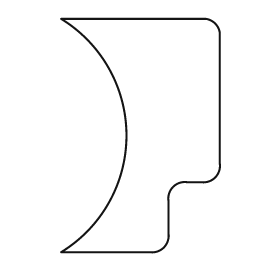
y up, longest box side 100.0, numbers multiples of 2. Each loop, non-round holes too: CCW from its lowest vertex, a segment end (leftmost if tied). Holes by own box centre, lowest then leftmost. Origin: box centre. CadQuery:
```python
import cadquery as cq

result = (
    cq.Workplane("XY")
    .moveTo(-34.0, -50.0)
    .lineTo(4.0, -50.0)
    .threePointArc((10.0, -48.0), (12.0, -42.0))
    .lineTo(12.0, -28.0)
    .threePointArc((14.0, -22.0), (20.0, -20.0))
    .lineTo(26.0, -20.0)
    .threePointArc((32.0, -18.0), (34.0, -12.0))
    .lineTo(34.0, 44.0)
    .threePointArc((32.0, 48.0), (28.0, 50.0))
    .lineTo(-34.0, 50.0)
    .threePointArc((-6.0, 0.0), (-34.0, -50.0))
    .close()
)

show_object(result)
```